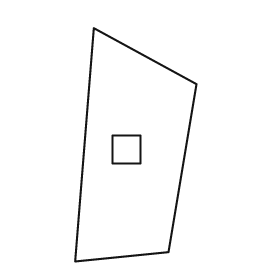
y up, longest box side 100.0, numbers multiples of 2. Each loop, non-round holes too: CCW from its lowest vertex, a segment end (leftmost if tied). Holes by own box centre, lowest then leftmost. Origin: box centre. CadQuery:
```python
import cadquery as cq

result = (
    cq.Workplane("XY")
    .moveTo(-26.0, -50.0)
    .lineTo(14.0, -46.0)
    .lineTo(26.0, 26.0)
    .lineTo(-18.0, 50.0)
    .close()
    .moveTo(-10.0, -8.0)
    .lineTo(2.0, -8.0)
    .lineTo(2.0, 4.0)
    .lineTo(-10.0, 4.0)
    .close()
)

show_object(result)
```